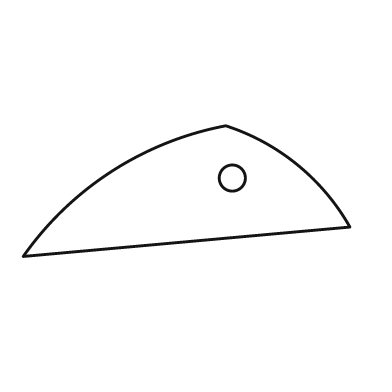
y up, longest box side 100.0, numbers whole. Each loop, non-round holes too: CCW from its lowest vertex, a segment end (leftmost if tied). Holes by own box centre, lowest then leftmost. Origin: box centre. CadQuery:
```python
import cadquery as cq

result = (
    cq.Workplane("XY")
    .moveTo(-50.0, -20.0)
    .lineTo(50.0, -11.0)
    .threePointArc((34.0, 8.0), (12.0, 20.0))
    .threePointArc((-23.0, 6.0), (-50.0, -20.0))
    .close()
    .moveTo(14.0, 4.0)
    .circle(4.0)
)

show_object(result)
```